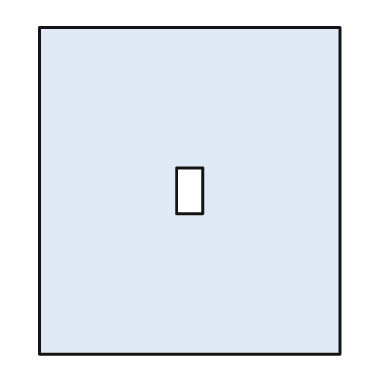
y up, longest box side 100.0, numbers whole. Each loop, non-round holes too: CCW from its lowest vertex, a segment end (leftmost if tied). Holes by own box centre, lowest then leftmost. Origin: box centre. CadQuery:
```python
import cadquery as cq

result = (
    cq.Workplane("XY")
    .moveTo(-46.0, -50.0)
    .lineTo(46.0, -50.0)
    .lineTo(46.0, 50.0)
    .lineTo(-46.0, 50.0)
    .close()
    .moveTo(-4.0, -7.0)
    .lineTo(4.0, -7.0)
    .lineTo(4.0, 7.0)
    .lineTo(-4.0, 7.0)
    .close()
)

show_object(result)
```